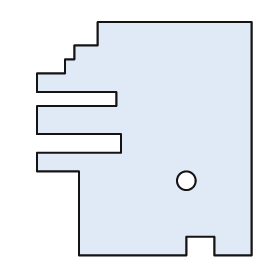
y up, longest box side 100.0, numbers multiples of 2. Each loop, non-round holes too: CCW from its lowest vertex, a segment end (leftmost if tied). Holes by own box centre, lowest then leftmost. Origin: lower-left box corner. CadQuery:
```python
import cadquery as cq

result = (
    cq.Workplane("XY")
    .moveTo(18.0, 0.0)
    .lineTo(64.0, 0.0)
    .lineTo(64.0, 8.0)
    .lineTo(76.0, 8.0)
    .lineTo(76.0, 0.0)
    .lineTo(92.0, 0.0)
    .lineTo(92.0, 100.0)
    .lineTo(26.0, 100.0)
    .lineTo(26.0, 90.0)
    .lineTo(16.0, 90.0)
    .lineTo(16.0, 84.0)
    .lineTo(12.0, 84.0)
    .lineTo(12.0, 78.0)
    .lineTo(0.0, 78.0)
    .lineTo(0.0, 70.0)
    .lineTo(34.0, 70.0)
    .lineTo(34.0, 64.0)
    .lineTo(0.0, 64.0)
    .lineTo(0.0, 52.0)
    .lineTo(36.0, 52.0)
    .lineTo(36.0, 44.0)
    .lineTo(0.0, 44.0)
    .lineTo(0.0, 36.0)
    .lineTo(18.0, 36.0)
    .close()
    .moveTo(64.0, 32.0)
    .circle(4.0)
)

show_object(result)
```